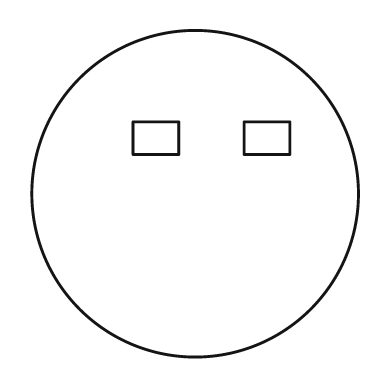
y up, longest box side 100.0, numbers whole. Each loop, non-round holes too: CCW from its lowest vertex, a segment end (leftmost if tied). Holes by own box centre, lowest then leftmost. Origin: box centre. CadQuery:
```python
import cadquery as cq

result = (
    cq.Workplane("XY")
    .moveTo(0.0, 0.0)
    .circle(50.0)
    .moveTo(-19.0, 12.0)
    .lineTo(-5.0, 12.0)
    .lineTo(-5.0, 22.0)
    .lineTo(-19.0, 22.0)
    .close()
    .moveTo(15.0, 12.0)
    .lineTo(29.0, 12.0)
    .lineTo(29.0, 22.0)
    .lineTo(15.0, 22.0)
    .close()
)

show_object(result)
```